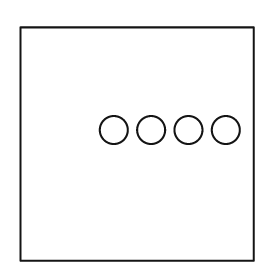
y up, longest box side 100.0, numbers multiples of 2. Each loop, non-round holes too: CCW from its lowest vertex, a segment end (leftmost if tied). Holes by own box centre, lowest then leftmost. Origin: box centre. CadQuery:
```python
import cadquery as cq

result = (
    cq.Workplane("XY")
    .moveTo(-50.0, -50.0)
    .lineTo(50.0, -50.0)
    .lineTo(50.0, 50.0)
    .lineTo(-50.0, 50.0)
    .close()
    .moveTo(-10.0, 6.0)
    .circle(6.0)
    .moveTo(6.0, 6.0)
    .circle(6.0)
    .moveTo(22.0, 6.0)
    .circle(6.0)
    .moveTo(38.0, 6.0)
    .circle(6.0)
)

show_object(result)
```